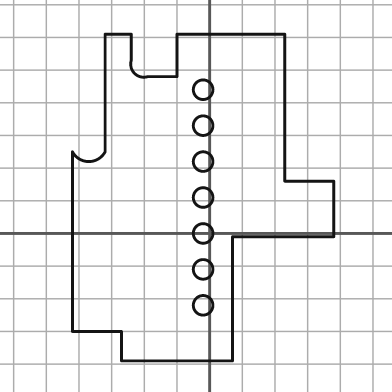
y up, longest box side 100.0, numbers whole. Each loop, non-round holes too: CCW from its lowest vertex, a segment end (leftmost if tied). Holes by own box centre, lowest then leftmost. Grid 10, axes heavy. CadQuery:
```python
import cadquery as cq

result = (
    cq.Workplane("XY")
    .moveTo(-27.0, -39.0)
    .lineTo(7.0, -39.0)
    .lineTo(7.0, -1.0)
    .lineTo(38.0, -1.0)
    .lineTo(38.0, 16.0)
    .lineTo(23.0, 16.0)
    .lineTo(23.0, 61.0)
    .lineTo(-10.0, 61.0)
    .lineTo(-10.0, 48.0)
    .lineTo(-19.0, 48.0)
    .threePointArc((-23.0, 49.0), (-24.0, 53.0))
    .lineTo(-24.0, 61.0)
    .lineTo(-32.0, 61.0)
    .lineTo(-32.0, 25.0)
    .threePointArc((-37.0, 22.0), (-42.0, 25.0))
    .lineTo(-42.0, -30.0)
    .lineTo(-27.0, -30.0)
    .close()
    .moveTo(-2.0, -22.0)
    .circle(3.0)
    .moveTo(-2.0, -11.0)
    .circle(3.0)
    .moveTo(-2.0, 0.0)
    .circle(3.0)
    .moveTo(-2.0, 11.0)
    .circle(3.0)
    .moveTo(-2.0, 22.0)
    .circle(3.0)
    .moveTo(-2.0, 33.0)
    .circle(3.0)
    .moveTo(-2.0, 44.0)
    .circle(3.0)
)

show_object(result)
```